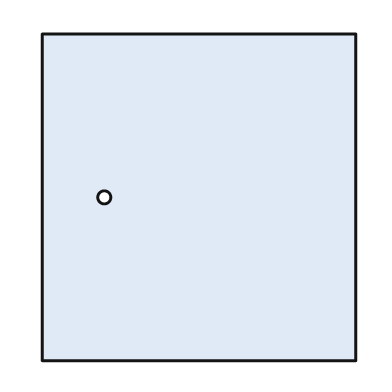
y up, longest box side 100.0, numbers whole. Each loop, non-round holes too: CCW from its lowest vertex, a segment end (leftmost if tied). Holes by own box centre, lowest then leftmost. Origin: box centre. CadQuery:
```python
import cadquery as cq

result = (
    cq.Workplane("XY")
    .moveTo(-48.0, -50.0)
    .lineTo(48.0, -50.0)
    .lineTo(48.0, 50.0)
    .lineTo(-48.0, 50.0)
    .close()
    .moveTo(-29.0, 0.0)
    .circle(2.0)
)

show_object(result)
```